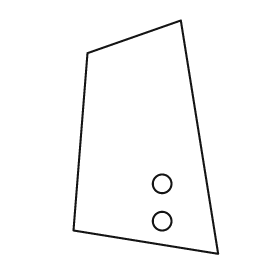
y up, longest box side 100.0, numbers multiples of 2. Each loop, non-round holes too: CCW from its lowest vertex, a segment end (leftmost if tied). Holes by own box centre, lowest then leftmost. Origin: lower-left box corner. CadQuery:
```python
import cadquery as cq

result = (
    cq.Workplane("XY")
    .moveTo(62.0, 0.0)
    .lineTo(46.0, 100.0)
    .lineTo(6.0, 86.0)
    .lineTo(0.0, 10.0)
    .close()
    .moveTo(38.0, 14.0)
    .circle(4.0)
    .moveTo(38.0, 30.0)
    .circle(4.0)
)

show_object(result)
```